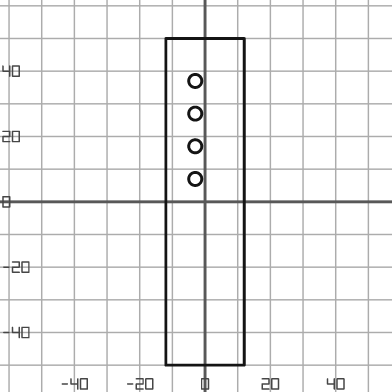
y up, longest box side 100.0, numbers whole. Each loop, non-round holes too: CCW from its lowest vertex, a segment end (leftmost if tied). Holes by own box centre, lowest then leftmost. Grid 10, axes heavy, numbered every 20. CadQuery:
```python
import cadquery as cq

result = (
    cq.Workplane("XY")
    .moveTo(-12.0, -50.0)
    .lineTo(12.0, -50.0)
    .lineTo(12.0, 50.0)
    .lineTo(-12.0, 50.0)
    .close()
    .moveTo(-3.0, 7.0)
    .circle(2.0)
    .moveTo(-3.0, 17.0)
    .circle(2.0)
    .moveTo(-3.0, 27.0)
    .circle(2.0)
    .moveTo(-3.0, 37.0)
    .circle(2.0)
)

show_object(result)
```